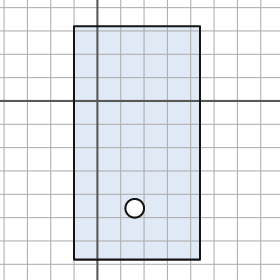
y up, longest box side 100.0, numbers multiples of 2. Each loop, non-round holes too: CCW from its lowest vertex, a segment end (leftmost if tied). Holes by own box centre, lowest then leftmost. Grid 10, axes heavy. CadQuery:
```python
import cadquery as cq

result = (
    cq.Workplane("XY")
    .moveTo(-10.0, -68.0)
    .lineTo(44.0, -68.0)
    .lineTo(44.0, 32.0)
    .lineTo(-10.0, 32.0)
    .close()
    .moveTo(16.0, -46.0)
    .circle(4.0)
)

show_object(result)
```